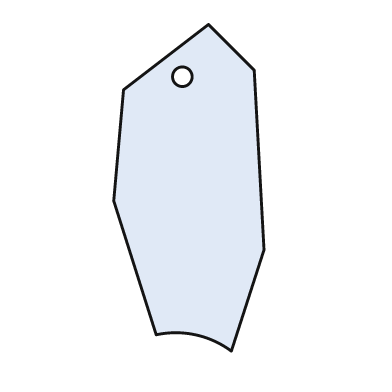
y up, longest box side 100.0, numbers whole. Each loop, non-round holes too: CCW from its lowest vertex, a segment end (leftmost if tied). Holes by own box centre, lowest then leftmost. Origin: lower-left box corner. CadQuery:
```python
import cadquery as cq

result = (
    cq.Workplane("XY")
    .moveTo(36.0, 0.0)
    .lineTo(46.0, 31.0)
    .lineTo(43.0, 86.0)
    .lineTo(29.0, 100.0)
    .lineTo(3.0, 80.0)
    .lineTo(0.0, 46.0)
    .lineTo(13.0, 5.0)
    .threePointArc((25.0, 5.0), (36.0, 0.0))
    .close()
    .moveTo(21.0, 84.0)
    .circle(3.0)
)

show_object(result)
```